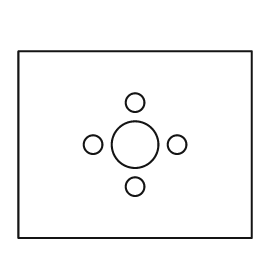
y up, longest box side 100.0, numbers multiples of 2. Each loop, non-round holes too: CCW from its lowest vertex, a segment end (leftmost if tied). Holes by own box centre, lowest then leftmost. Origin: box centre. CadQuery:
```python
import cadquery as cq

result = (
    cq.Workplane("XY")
    .moveTo(-50.0, -40.0)
    .lineTo(50.0, -40.0)
    .lineTo(50.0, 40.0)
    .lineTo(-50.0, 40.0)
    .close()
    .moveTo(0.0, -18.0)
    .circle(4.0)
    .moveTo(-18.0, 0.0)
    .circle(4.0)
    .moveTo(0.0, 0.0)
    .circle(10.0)
    .moveTo(18.0, 0.0)
    .circle(4.0)
    .moveTo(0.0, 18.0)
    .circle(4.0)
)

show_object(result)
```